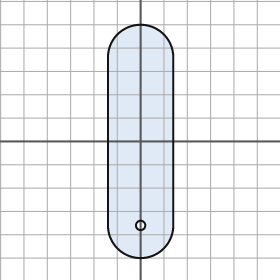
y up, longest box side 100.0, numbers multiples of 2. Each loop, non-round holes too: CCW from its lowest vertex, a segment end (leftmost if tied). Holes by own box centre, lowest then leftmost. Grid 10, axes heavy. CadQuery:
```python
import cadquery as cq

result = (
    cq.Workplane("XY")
    .moveTo(-14.0, -36.0)
    .threePointArc((0.0, -50.0), (14.0, -36.0))
    .lineTo(14.0, 36.0)
    .threePointArc((0.0, 50.0), (-14.0, 36.0))
    .close()
    .moveTo(0.0, -36.0)
    .circle(2.0)
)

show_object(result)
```